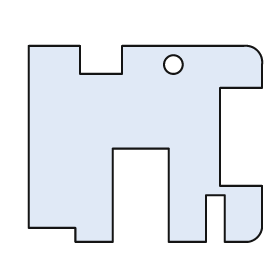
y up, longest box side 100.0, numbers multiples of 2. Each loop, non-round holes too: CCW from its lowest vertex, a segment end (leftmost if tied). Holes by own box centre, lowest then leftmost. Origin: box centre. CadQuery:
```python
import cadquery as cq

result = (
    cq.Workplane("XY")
    .moveTo(-30.0, -42.0)
    .lineTo(-14.0, -42.0)
    .lineTo(-14.0, -2.0)
    .lineTo(10.0, -2.0)
    .lineTo(10.0, -42.0)
    .lineTo(26.0, -42.0)
    .lineTo(26.0, -22.0)
    .lineTo(34.0, -22.0)
    .lineTo(34.0, -42.0)
    .lineTo(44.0, -42.0)
    .threePointArc((48.0, -40.0), (50.0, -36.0))
    .lineTo(50.0, -18.0)
    .lineTo(32.0, -18.0)
    .lineTo(32.0, 24.0)
    .lineTo(50.0, 24.0)
    .lineTo(50.0, 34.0)
    .threePointArc((48.0, 40.0), (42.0, 42.0))
    .lineTo(-10.0, 42.0)
    .lineTo(-10.0, 30.0)
    .lineTo(-28.0, 30.0)
    .lineTo(-28.0, 42.0)
    .lineTo(-50.0, 42.0)
    .lineTo(-50.0, -36.0)
    .lineTo(-30.0, -36.0)
    .close()
    .moveTo(12.0, 34.0)
    .circle(4.0)
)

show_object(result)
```